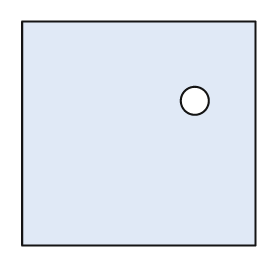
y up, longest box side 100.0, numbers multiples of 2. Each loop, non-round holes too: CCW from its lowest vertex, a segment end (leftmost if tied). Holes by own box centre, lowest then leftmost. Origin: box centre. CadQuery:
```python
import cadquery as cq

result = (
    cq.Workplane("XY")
    .moveTo(-50.0, -48.0)
    .lineTo(50.0, -48.0)
    .lineTo(50.0, 48.0)
    .lineTo(-50.0, 48.0)
    .close()
    .moveTo(24.0, 14.0)
    .circle(6.0)
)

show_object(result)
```